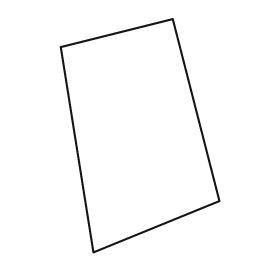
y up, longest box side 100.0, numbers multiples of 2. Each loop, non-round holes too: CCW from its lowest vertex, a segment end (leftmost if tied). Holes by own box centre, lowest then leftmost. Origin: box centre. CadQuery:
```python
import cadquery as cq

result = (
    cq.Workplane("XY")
    .moveTo(-20.0, -50.0)
    .lineTo(34.0, -28.0)
    .lineTo(14.0, 50.0)
    .lineTo(-34.0, 38.0)
    .close()
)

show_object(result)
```